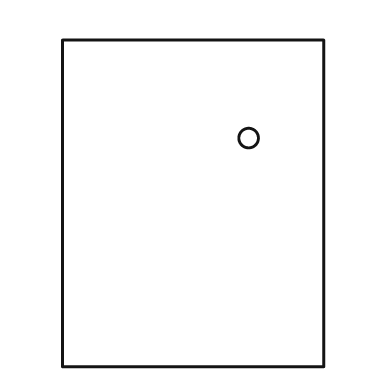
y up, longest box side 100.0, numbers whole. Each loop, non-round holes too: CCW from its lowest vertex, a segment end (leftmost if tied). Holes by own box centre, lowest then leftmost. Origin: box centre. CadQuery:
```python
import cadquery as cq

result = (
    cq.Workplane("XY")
    .moveTo(-40.0, -50.0)
    .lineTo(40.0, -50.0)
    .lineTo(40.0, 50.0)
    .lineTo(-40.0, 50.0)
    .close()
    .moveTo(17.0, 20.0)
    .circle(3.0)
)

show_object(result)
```